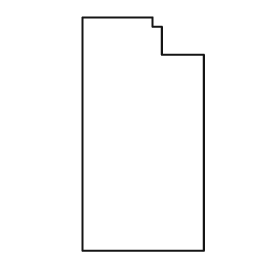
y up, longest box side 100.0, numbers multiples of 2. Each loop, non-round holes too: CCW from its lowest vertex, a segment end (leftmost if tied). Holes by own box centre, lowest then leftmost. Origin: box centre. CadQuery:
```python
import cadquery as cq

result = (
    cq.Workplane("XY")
    .moveTo(-26.0, -50.0)
    .lineTo(26.0, -50.0)
    .lineTo(26.0, 34.0)
    .lineTo(8.0, 34.0)
    .lineTo(8.0, 46.0)
    .lineTo(4.0, 46.0)
    .lineTo(4.0, 50.0)
    .lineTo(-26.0, 50.0)
    .close()
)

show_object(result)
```